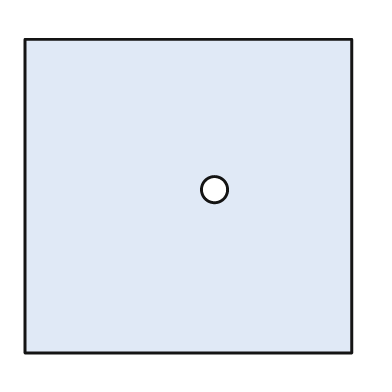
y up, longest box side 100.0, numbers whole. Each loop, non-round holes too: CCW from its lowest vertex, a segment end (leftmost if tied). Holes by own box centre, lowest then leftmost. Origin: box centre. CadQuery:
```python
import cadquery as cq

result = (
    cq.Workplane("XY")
    .moveTo(-50.0, -48.0)
    .lineTo(50.0, -48.0)
    .lineTo(50.0, 48.0)
    .lineTo(-50.0, 48.0)
    .close()
    .moveTo(8.0, 2.0)
    .circle(4.0)
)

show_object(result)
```